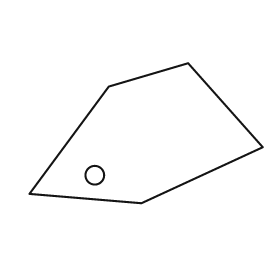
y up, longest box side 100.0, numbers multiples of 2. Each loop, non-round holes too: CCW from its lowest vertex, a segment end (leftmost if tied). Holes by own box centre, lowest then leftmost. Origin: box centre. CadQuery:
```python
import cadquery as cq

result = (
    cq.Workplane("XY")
    .moveTo(-2.0, -30.0)
    .lineTo(50.0, -6.0)
    .lineTo(18.0, 30.0)
    .lineTo(-16.0, 20.0)
    .lineTo(-50.0, -26.0)
    .close()
    .moveTo(-22.0, -18.0)
    .circle(4.0)
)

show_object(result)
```